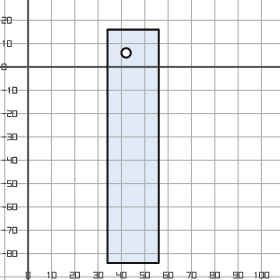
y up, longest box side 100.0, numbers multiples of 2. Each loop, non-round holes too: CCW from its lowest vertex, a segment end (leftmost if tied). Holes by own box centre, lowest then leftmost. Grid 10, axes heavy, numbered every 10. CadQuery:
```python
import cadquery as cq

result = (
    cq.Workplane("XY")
    .moveTo(34.0, -84.0)
    .lineTo(56.0, -84.0)
    .lineTo(56.0, 16.0)
    .lineTo(34.0, 16.0)
    .close()
    .moveTo(42.0, 6.0)
    .circle(2.0)
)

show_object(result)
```